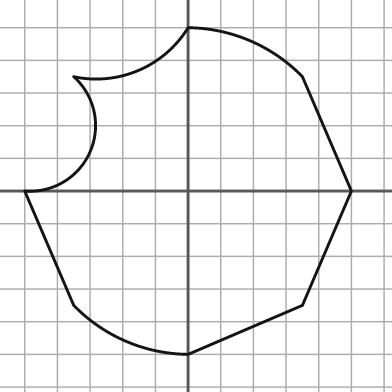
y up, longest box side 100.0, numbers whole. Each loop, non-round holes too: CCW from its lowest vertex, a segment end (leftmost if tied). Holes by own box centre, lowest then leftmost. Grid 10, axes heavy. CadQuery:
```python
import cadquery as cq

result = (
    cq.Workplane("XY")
    .moveTo(0.0, -50.0)
    .lineTo(35.0, -35.0)
    .lineTo(50.0, 0.0)
    .lineTo(35.0, 35.0)
    .threePointArc((19.0, 46.0), (0.0, 50.0))
    .threePointArc((-15.0, 37.0), (-35.0, 35.0))
    .threePointArc((-30.0, 12.0), (-50.0, 0.0))
    .lineTo(-35.0, -35.0)
    .threePointArc((-19.0, -46.0), (0.0, -50.0))
    .close()
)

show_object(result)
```